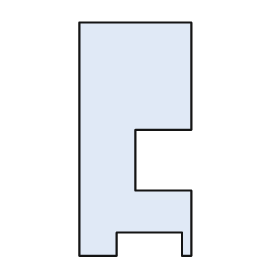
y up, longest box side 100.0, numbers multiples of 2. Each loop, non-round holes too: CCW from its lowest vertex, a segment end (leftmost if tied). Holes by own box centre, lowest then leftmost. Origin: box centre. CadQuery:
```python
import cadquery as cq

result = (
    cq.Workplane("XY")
    .moveTo(-24.0, -50.0)
    .lineTo(-8.0, -50.0)
    .lineTo(-8.0, -40.0)
    .lineTo(20.0, -40.0)
    .lineTo(20.0, -50.0)
    .lineTo(24.0, -50.0)
    .lineTo(24.0, -22.0)
    .lineTo(0.0, -22.0)
    .lineTo(0.0, 4.0)
    .lineTo(24.0, 4.0)
    .lineTo(24.0, 50.0)
    .lineTo(-24.0, 50.0)
    .close()
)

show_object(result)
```